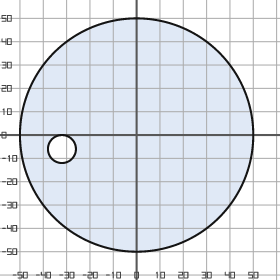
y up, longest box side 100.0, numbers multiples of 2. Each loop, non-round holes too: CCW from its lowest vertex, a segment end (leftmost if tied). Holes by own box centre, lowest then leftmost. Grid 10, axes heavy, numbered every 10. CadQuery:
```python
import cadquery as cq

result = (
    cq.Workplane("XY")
    .moveTo(0.0, 0.0)
    .circle(50.0)
    .moveTo(-32.0, -6.0)
    .circle(6.0)
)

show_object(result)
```